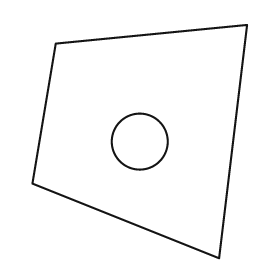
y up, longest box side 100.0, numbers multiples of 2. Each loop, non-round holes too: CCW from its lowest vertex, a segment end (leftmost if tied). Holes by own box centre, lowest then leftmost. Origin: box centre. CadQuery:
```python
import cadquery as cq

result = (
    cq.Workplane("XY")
    .moveTo(34.0, -50.0)
    .lineTo(46.0, 50.0)
    .lineTo(-36.0, 42.0)
    .lineTo(-46.0, -18.0)
    .close()
    .moveTo(0.0, 0.0)
    .circle(12.0)
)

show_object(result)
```